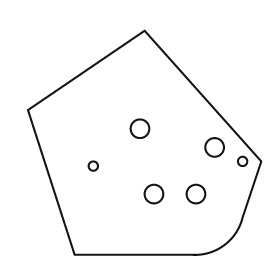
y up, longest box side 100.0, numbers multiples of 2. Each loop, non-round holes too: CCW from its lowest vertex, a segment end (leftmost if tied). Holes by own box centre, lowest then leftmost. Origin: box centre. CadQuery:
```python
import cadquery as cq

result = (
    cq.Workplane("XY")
    .moveTo(-30.0, -48.0)
    .lineTo(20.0, -48.0)
    .threePointArc((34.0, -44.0), (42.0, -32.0))
    .lineTo(50.0, -8.0)
    .lineTo(0.0, 48.0)
    .lineTo(-50.0, 14.0)
    .close()
    .moveTo(4.0, -22.0)
    .circle(4.0)
    .moveTo(22.0, -22.0)
    .circle(4.0)
    .moveTo(-22.0, -10.0)
    .circle(2.0)
    .moveTo(42.0, -8.0)
    .circle(2.0)
    .moveTo(30.0, -2.0)
    .circle(4.0)
    .moveTo(-2.0, 6.0)
    .circle(4.0)
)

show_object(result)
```